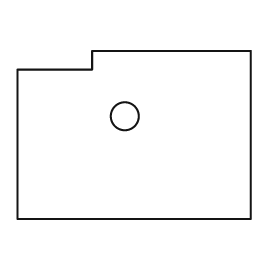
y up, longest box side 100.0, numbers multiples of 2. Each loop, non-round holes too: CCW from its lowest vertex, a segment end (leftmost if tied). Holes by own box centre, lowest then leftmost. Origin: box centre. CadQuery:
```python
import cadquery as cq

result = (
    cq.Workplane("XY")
    .moveTo(-50.0, -36.0)
    .lineTo(50.0, -36.0)
    .lineTo(50.0, 36.0)
    .lineTo(-18.0, 36.0)
    .lineTo(-18.0, 28.0)
    .lineTo(-50.0, 28.0)
    .close()
    .moveTo(-4.0, 8.0)
    .circle(6.0)
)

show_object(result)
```